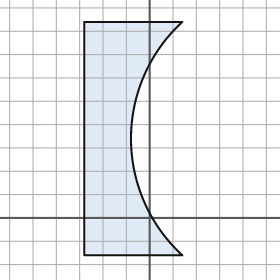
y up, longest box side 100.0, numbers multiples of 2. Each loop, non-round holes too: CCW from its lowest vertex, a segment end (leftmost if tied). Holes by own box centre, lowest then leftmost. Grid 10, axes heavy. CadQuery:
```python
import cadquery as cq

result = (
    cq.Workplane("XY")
    .moveTo(-28.0, -16.0)
    .lineTo(14.0, -16.0)
    .threePointArc((-8.0, 34.0), (14.0, 84.0))
    .lineTo(-28.0, 84.0)
    .close()
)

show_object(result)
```